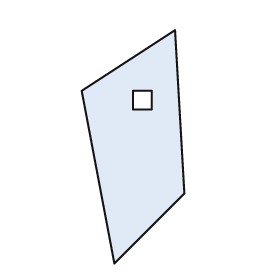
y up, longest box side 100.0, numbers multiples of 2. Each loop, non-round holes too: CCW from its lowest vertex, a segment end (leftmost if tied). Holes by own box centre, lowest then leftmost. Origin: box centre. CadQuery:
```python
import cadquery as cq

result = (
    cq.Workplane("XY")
    .moveTo(-8.0, -50.0)
    .lineTo(22.0, -20.0)
    .lineTo(18.0, 50.0)
    .lineTo(-22.0, 24.0)
    .close()
    .moveTo(0.0, 16.0)
    .lineTo(8.0, 16.0)
    .lineTo(8.0, 24.0)
    .lineTo(0.0, 24.0)
    .close()
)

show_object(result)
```